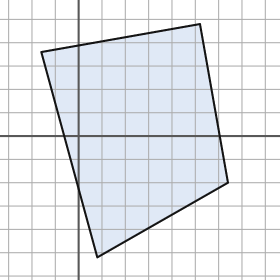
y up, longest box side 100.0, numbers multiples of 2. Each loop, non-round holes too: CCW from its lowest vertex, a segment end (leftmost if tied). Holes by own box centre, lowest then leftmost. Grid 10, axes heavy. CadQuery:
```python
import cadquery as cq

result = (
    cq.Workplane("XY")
    .moveTo(8.0, -52.0)
    .lineTo(64.0, -20.0)
    .lineTo(52.0, 48.0)
    .lineTo(-16.0, 36.0)
    .close()
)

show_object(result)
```